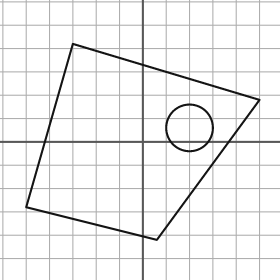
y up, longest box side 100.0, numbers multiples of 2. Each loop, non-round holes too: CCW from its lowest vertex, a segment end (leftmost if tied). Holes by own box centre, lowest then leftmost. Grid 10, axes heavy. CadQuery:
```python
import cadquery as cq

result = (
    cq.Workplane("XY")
    .moveTo(6.0, -42.0)
    .lineTo(50.0, 18.0)
    .lineTo(-30.0, 42.0)
    .lineTo(-50.0, -28.0)
    .close()
    .moveTo(20.0, 6.0)
    .circle(10.0)
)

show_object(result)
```